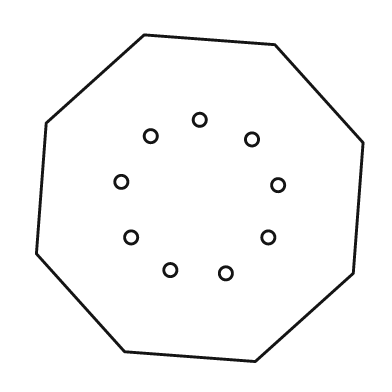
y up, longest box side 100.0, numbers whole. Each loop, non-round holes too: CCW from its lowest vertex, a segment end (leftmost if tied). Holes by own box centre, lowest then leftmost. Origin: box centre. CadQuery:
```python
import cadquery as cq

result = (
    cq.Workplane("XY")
    .moveTo(17.0, -50.0)
    .lineTo(47.0, -23.0)
    .lineTo(50.0, 17.0)
    .lineTo(23.0, 47.0)
    .lineTo(-17.0, 50.0)
    .lineTo(-47.0, 23.0)
    .lineTo(-50.0, -17.0)
    .lineTo(-23.0, -47.0)
    .close()
    .moveTo(8.0, -23.0)
    .circle(2.0)
    .moveTo(-9.0, -22.0)
    .circle(2.0)
    .moveTo(-21.0, -12.0)
    .circle(2.0)
    .moveTo(21.0, -12.0)
    .circle(2.0)
    .moveTo(24.0, 4.0)
    .circle(2.0)
    .moveTo(-24.0, 5.0)
    .circle(2.0)
    .moveTo(16.0, 18.0)
    .circle(2.0)
    .moveTo(-15.0, 19.0)
    .circle(2.0)
    .moveTo(0.0, 24.0)
    .circle(2.0)
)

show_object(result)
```